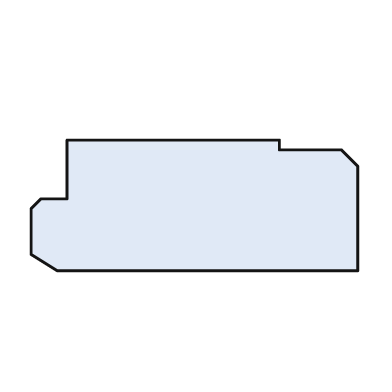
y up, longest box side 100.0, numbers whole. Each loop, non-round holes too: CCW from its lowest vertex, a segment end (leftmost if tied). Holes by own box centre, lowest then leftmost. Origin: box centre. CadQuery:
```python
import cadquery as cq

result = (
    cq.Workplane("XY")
    .moveTo(-42.0, -20.0)
    .lineTo(50.0, -20.0)
    .lineTo(50.0, 12.0)
    .lineTo(45.0, 17.0)
    .lineTo(26.0, 17.0)
    .lineTo(26.0, 20.0)
    .lineTo(-39.0, 20.0)
    .lineTo(-39.0, 2.0)
    .lineTo(-47.0, 2.0)
    .lineTo(-50.0, -1.0)
    .lineTo(-50.0, -15.0)
    .close()
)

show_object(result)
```